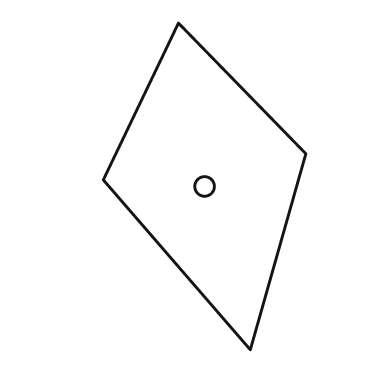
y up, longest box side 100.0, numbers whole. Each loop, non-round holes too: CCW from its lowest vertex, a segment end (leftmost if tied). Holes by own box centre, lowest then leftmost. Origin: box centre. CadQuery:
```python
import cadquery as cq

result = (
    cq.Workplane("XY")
    .moveTo(14.0, -50.0)
    .lineTo(31.0, 10.0)
    .lineTo(-8.0, 50.0)
    .lineTo(-31.0, 2.0)
    .close()
    .moveTo(0.0, 0.0)
    .circle(3.0)
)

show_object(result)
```